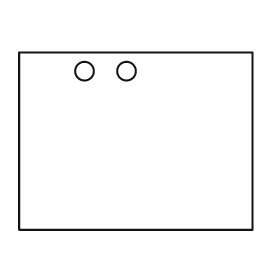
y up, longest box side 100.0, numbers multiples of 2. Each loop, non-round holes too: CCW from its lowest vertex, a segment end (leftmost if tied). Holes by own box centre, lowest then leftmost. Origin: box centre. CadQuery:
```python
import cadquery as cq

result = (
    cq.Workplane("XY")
    .moveTo(-50.0, -38.0)
    .lineTo(50.0, -38.0)
    .lineTo(50.0, 38.0)
    .lineTo(-50.0, 38.0)
    .close()
    .moveTo(-22.0, 30.0)
    .circle(4.0)
    .moveTo(-4.0, 30.0)
    .circle(4.0)
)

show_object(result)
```